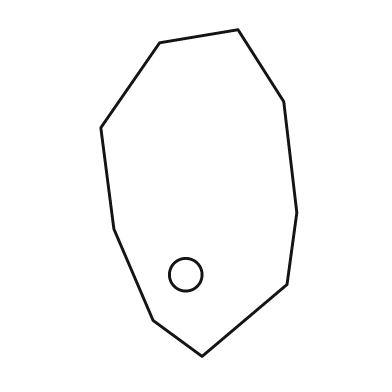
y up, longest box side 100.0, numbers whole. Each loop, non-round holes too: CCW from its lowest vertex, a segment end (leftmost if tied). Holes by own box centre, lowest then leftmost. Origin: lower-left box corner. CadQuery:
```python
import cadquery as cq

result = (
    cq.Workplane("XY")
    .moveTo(31.0, 0.0)
    .lineTo(57.0, 22.0)
    .lineTo(60.0, 44.0)
    .lineTo(56.0, 78.0)
    .lineTo(42.0, 100.0)
    .lineTo(18.0, 96.0)
    .lineTo(0.0, 70.0)
    .lineTo(4.0, 39.0)
    .lineTo(16.0, 11.0)
    .close()
    .moveTo(26.0, 25.0)
    .circle(5.0)
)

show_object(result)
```